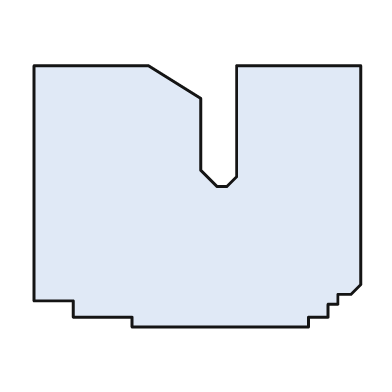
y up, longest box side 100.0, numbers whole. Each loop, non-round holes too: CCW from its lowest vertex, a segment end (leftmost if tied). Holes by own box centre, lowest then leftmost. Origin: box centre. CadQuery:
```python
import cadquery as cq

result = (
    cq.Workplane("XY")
    .moveTo(-20.0, -40.0)
    .lineTo(34.0, -40.0)
    .lineTo(34.0, -37.0)
    .lineTo(40.0, -37.0)
    .lineTo(40.0, -33.0)
    .lineTo(43.0, -33.0)
    .lineTo(43.0, -30.0)
    .lineTo(47.0, -30.0)
    .lineTo(50.0, -27.0)
    .lineTo(50.0, 40.0)
    .lineTo(12.0, 40.0)
    .lineTo(12.0, 6.0)
    .lineTo(9.0, 3.0)
    .lineTo(6.0, 3.0)
    .lineTo(1.0, 8.0)
    .lineTo(1.0, 30.0)
    .lineTo(-15.0, 40.0)
    .lineTo(-50.0, 40.0)
    .lineTo(-50.0, -32.0)
    .lineTo(-38.0, -32.0)
    .lineTo(-38.0, -37.0)
    .lineTo(-20.0, -37.0)
    .close()
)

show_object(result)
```